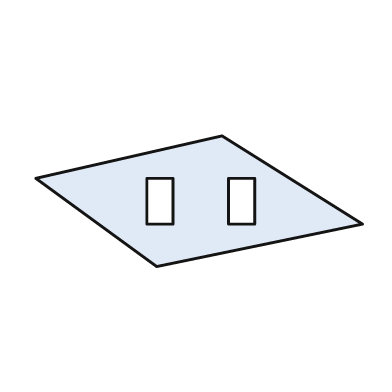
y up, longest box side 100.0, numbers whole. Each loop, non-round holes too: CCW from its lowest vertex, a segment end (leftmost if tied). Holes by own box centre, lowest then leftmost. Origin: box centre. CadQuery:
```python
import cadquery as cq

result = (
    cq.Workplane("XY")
    .moveTo(-13.0, -20.0)
    .lineTo(50.0, -7.0)
    .lineTo(7.0, 20.0)
    .lineTo(-50.0, 7.0)
    .close()
    .moveTo(-16.0, -7.0)
    .lineTo(-8.0, -7.0)
    .lineTo(-8.0, 7.0)
    .lineTo(-16.0, 7.0)
    .close()
    .moveTo(9.0, -7.0)
    .lineTo(17.0, -7.0)
    .lineTo(17.0, 7.0)
    .lineTo(9.0, 7.0)
    .close()
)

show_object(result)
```